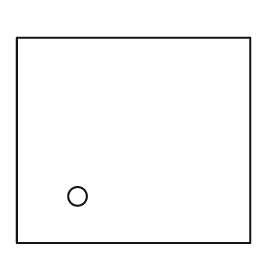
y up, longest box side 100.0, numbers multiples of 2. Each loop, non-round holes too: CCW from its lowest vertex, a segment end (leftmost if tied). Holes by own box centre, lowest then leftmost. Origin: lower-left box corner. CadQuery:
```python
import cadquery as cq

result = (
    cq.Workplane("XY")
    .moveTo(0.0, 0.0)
    .lineTo(100.0, 0.0)
    .lineTo(100.0, 88.0)
    .lineTo(0.0, 88.0)
    .close()
    .moveTo(26.0, 20.0)
    .circle(4.0)
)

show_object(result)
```